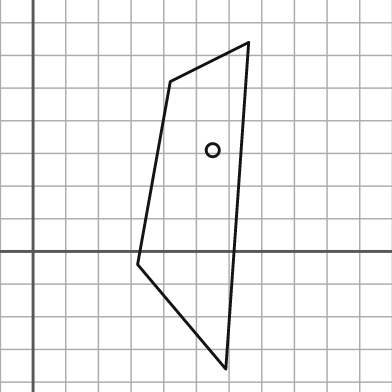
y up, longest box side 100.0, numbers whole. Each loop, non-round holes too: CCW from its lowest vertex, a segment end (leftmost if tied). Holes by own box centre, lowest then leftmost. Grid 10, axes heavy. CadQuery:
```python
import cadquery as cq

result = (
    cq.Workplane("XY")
    .moveTo(59.0, -36.0)
    .lineTo(66.0, 64.0)
    .lineTo(42.0, 52.0)
    .lineTo(32.0, -4.0)
    .close()
    .moveTo(55.0, 31.0)
    .circle(2.0)
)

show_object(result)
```